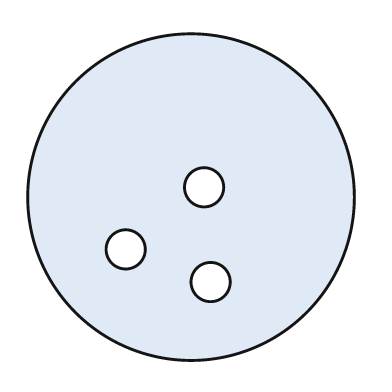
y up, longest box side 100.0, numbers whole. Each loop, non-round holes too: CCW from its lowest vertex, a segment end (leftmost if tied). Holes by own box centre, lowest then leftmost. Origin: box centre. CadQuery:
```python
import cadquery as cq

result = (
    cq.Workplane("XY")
    .moveTo(0.0, 0.0)
    .circle(50.0)
    .moveTo(6.0, -26.0)
    .circle(6.0)
    .moveTo(-20.0, -16.0)
    .circle(6.0)
    .moveTo(4.0, 3.0)
    .circle(6.0)
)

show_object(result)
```